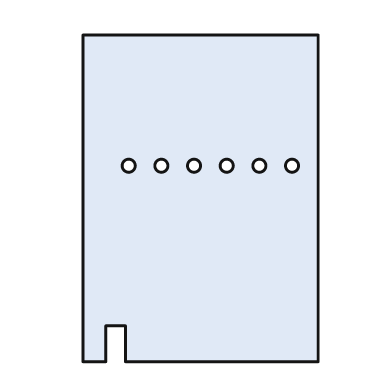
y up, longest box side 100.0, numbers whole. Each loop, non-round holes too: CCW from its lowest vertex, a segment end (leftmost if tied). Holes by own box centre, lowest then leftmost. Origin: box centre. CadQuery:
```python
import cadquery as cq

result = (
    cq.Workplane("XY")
    .moveTo(-36.0, -50.0)
    .lineTo(-29.0, -50.0)
    .lineTo(-29.0, -39.0)
    .lineTo(-23.0, -39.0)
    .lineTo(-23.0, -50.0)
    .lineTo(36.0, -50.0)
    .lineTo(36.0, 50.0)
    .lineTo(-36.0, 50.0)
    .close()
    .moveTo(-22.0, 10.0)
    .circle(2.0)
    .moveTo(-12.0, 10.0)
    .circle(2.0)
    .moveTo(-2.0, 10.0)
    .circle(2.0)
    .moveTo(8.0, 10.0)
    .circle(2.0)
    .moveTo(18.0, 10.0)
    .circle(2.0)
    .moveTo(28.0, 10.0)
    .circle(2.0)
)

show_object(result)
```